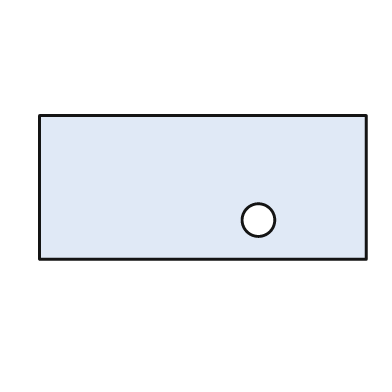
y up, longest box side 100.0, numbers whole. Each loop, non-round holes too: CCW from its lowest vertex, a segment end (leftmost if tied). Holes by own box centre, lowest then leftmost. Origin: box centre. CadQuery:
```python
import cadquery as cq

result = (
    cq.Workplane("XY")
    .moveTo(-50.0, -22.0)
    .lineTo(50.0, -22.0)
    .lineTo(50.0, 22.0)
    .lineTo(-50.0, 22.0)
    .close()
    .moveTo(17.0, -10.0)
    .circle(5.0)
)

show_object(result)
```